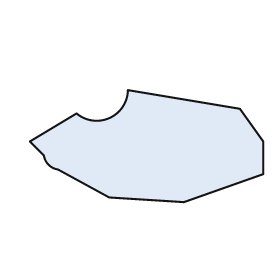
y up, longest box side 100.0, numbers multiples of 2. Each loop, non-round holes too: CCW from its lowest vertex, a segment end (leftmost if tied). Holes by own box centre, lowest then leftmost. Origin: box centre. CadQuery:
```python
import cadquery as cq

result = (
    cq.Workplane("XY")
    .moveTo(16.0, -24.0)
    .lineTo(50.0, -12.0)
    .lineTo(50.0, 2.0)
    .lineTo(40.0, 16.0)
    .lineTo(-8.0, 24.0)
    .threePointArc((-16.0, 12.0), (-30.0, 14.0))
    .lineTo(-50.0, 2.0)
    .lineTo(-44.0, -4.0)
    .threePointArc((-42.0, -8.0), (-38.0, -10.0))
    .lineTo(-16.0, -22.0)
    .close()
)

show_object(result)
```